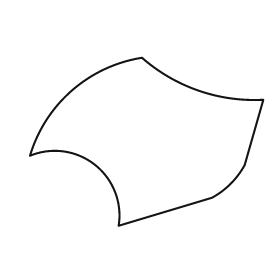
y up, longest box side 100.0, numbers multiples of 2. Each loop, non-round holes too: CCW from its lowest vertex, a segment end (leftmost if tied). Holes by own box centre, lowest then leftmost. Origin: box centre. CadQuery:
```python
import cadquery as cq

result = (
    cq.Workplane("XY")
    .moveTo(-12.0, -36.0)
    .lineTo(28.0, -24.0)
    .threePointArc((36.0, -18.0), (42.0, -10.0))
    .lineTo(50.0, 18.0)
    .threePointArc((22.0, 22.0), (-2.0, 36.0))
    .threePointArc((-32.0, 22.0), (-50.0, -6.0))
    .threePointArc((-22.0, -10.0), (-12.0, -36.0))
    .close()
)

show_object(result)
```